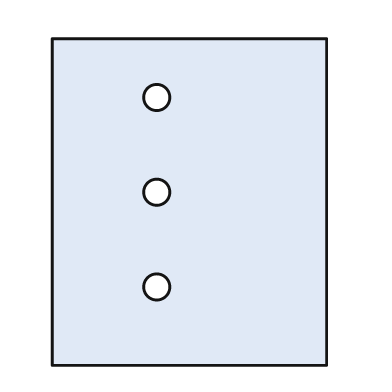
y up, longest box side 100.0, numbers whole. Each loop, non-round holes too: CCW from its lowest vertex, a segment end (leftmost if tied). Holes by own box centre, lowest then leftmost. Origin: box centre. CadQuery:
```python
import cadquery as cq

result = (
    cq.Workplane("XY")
    .moveTo(-42.0, -50.0)
    .lineTo(42.0, -50.0)
    .lineTo(42.0, 50.0)
    .lineTo(-42.0, 50.0)
    .close()
    .moveTo(-10.0, -26.0)
    .circle(4.0)
    .moveTo(-10.0, 3.0)
    .circle(4.0)
    .moveTo(-10.0, 32.0)
    .circle(4.0)
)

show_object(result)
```